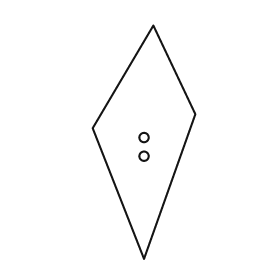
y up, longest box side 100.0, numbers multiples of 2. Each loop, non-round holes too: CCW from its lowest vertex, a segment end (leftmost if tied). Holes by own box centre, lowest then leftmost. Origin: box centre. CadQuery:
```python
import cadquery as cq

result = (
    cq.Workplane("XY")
    .moveTo(0.0, -50.0)
    .lineTo(22.0, 12.0)
    .lineTo(4.0, 50.0)
    .lineTo(-22.0, 6.0)
    .close()
    .moveTo(0.0, -6.0)
    .circle(2.0)
    .moveTo(0.0, 2.0)
    .circle(2.0)
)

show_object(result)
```